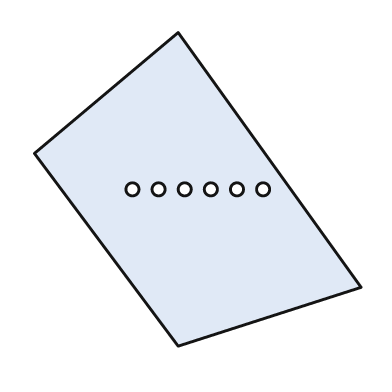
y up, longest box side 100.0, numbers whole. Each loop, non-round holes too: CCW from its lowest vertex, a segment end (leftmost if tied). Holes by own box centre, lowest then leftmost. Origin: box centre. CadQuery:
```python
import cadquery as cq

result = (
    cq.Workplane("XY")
    .moveTo(-6.0, -48.0)
    .lineTo(50.0, -30.0)
    .lineTo(-6.0, 48.0)
    .lineTo(-50.0, 11.0)
    .close()
    .moveTo(-20.0, 0.0)
    .circle(2.0)
    .moveTo(-12.0, 0.0)
    .circle(2.0)
    .moveTo(-4.0, 0.0)
    .circle(2.0)
    .moveTo(4.0, 0.0)
    .circle(2.0)
    .moveTo(12.0, 0.0)
    .circle(2.0)
    .moveTo(20.0, 0.0)
    .circle(2.0)
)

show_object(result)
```